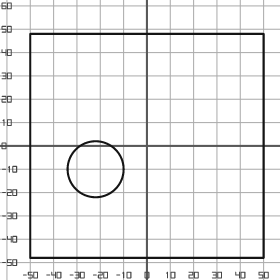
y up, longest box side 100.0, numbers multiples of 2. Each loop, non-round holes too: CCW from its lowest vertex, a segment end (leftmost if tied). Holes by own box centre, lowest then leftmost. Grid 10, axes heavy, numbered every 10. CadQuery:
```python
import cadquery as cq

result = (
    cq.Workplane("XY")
    .moveTo(-50.0, -48.0)
    .lineTo(50.0, -48.0)
    .lineTo(50.0, 48.0)
    .lineTo(-50.0, 48.0)
    .close()
    .moveTo(-22.0, -10.0)
    .circle(12.0)
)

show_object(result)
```